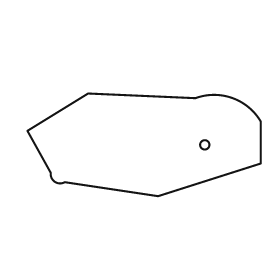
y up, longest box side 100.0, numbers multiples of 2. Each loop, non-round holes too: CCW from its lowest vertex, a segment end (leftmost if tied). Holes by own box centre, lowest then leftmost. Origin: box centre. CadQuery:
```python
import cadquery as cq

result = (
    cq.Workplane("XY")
    .moveTo(6.0, -22.0)
    .lineTo(50.0, -8.0)
    .lineTo(50.0, 10.0)
    .threePointArc((38.0, 20.0), (22.0, 20.0))
    .lineTo(-24.0, 22.0)
    .lineTo(-50.0, 6.0)
    .lineTo(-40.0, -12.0)
    .threePointArc((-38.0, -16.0), (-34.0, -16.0))
    .close()
    .moveTo(26.0, 0.0)
    .circle(2.0)
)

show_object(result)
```